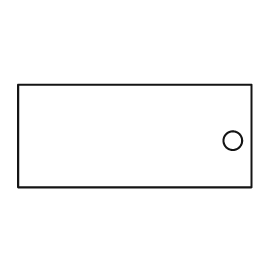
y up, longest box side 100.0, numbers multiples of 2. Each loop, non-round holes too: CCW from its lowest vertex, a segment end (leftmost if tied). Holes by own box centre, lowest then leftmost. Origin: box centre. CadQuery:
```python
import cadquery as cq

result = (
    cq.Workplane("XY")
    .moveTo(-50.0, -22.0)
    .lineTo(50.0, -22.0)
    .lineTo(50.0, 22.0)
    .lineTo(-50.0, 22.0)
    .close()
    .moveTo(42.0, -2.0)
    .circle(4.0)
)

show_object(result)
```